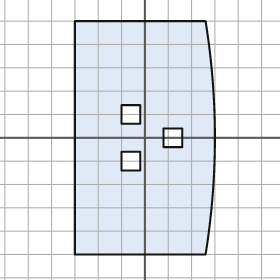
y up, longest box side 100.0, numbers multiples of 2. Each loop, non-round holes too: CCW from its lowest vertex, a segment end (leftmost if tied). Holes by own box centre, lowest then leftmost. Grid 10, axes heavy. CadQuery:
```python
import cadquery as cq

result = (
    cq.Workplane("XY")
    .moveTo(-30.0, -50.0)
    .lineTo(26.0, -50.0)
    .threePointArc((30.0, 0.0), (26.0, 50.0))
    .lineTo(-30.0, 50.0)
    .close()
    .moveTo(-10.0, -14.0)
    .lineTo(-2.0, -14.0)
    .lineTo(-2.0, -6.0)
    .lineTo(-10.0, -6.0)
    .close()
    .moveTo(8.0, -4.0)
    .lineTo(16.0, -4.0)
    .lineTo(16.0, 4.0)
    .lineTo(8.0, 4.0)
    .close()
    .moveTo(-10.0, 6.0)
    .lineTo(-2.0, 6.0)
    .lineTo(-2.0, 14.0)
    .lineTo(-10.0, 14.0)
    .close()
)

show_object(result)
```